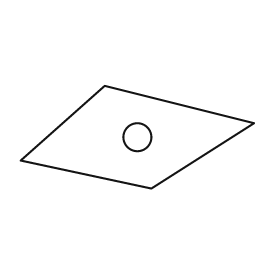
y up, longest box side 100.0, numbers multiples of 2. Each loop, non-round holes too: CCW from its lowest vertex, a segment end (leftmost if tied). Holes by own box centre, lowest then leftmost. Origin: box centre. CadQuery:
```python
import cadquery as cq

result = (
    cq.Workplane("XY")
    .moveTo(6.0, -22.0)
    .lineTo(50.0, 6.0)
    .lineTo(-14.0, 22.0)
    .lineTo(-50.0, -10.0)
    .close()
    .moveTo(0.0, 0.0)
    .circle(6.0)
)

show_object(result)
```